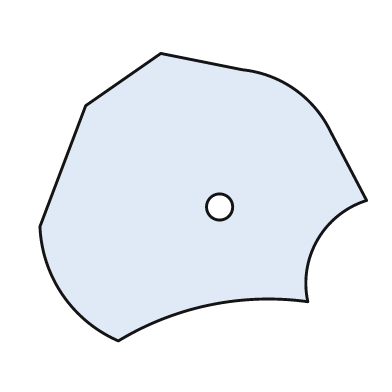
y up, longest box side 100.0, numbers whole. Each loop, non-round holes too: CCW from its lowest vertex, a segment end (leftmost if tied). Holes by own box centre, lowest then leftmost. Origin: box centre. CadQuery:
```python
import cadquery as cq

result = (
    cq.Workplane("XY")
    .moveTo(-26.0, -44.0)
    .threePointArc((2.0, -33.0), (32.0, -32.0))
    .threePointArc((35.0, -13.0), (50.0, -1.0))
    .lineTo(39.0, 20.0)
    .threePointArc((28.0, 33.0), (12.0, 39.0))
    .lineTo(-13.0, 44.0)
    .lineTo(-36.0, 28.0)
    .lineTo(-50.0, -9.0)
    .threePointArc((-43.0, -30.0), (-26.0, -44.0))
    .close()
    .moveTo(5.0, -3.0)
    .circle(4.0)
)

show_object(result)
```